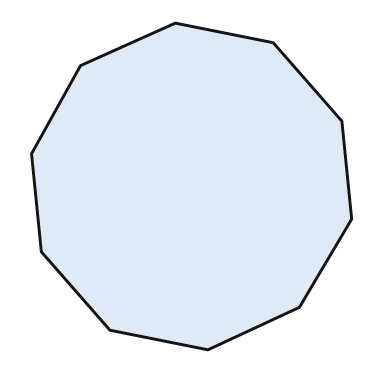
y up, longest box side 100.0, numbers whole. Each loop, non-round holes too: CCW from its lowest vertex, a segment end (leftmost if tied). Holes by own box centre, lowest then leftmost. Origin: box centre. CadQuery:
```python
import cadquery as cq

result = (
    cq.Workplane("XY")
    .moveTo(5.0, -50.0)
    .lineTo(33.0, -37.0)
    .lineTo(49.0, -10.0)
    .lineTo(46.0, 20.0)
    .lineTo(25.0, 44.0)
    .lineTo(-5.0, 50.0)
    .lineTo(-34.0, 37.0)
    .lineTo(-49.0, 10.0)
    .lineTo(-46.0, -20.0)
    .lineTo(-25.0, -44.0)
    .close()
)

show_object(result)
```